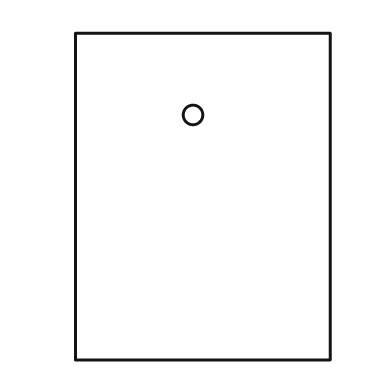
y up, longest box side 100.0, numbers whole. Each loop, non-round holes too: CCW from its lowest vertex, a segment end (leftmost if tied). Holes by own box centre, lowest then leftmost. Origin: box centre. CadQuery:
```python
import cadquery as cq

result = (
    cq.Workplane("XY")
    .moveTo(-39.0, -50.0)
    .lineTo(39.0, -50.0)
    .lineTo(39.0, 50.0)
    .lineTo(-39.0, 50.0)
    .close()
    .moveTo(-3.0, 25.0)
    .circle(3.0)
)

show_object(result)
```